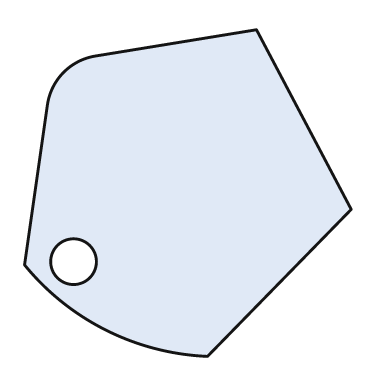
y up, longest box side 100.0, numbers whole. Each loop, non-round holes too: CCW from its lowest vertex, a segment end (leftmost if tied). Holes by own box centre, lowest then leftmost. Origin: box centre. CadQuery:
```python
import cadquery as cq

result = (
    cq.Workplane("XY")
    .moveTo(6.0, -50.0)
    .lineTo(50.0, -5.0)
    .lineTo(21.0, 50.0)
    .lineTo(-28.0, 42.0)
    .threePointArc((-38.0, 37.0), (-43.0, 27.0))
    .lineTo(-50.0, -22.0)
    .threePointArc((-25.0, -42.0), (6.0, -50.0))
    .close()
    .moveTo(-35.0, -21.0)
    .circle(7.0)
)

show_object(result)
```